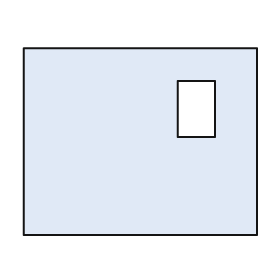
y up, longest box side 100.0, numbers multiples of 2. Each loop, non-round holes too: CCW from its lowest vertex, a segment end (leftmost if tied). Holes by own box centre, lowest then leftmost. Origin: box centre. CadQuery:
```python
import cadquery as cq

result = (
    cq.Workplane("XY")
    .moveTo(-50.0, -40.0)
    .lineTo(50.0, -40.0)
    .lineTo(50.0, 40.0)
    .lineTo(-50.0, 40.0)
    .close()
    .moveTo(16.0, 2.0)
    .lineTo(32.0, 2.0)
    .lineTo(32.0, 26.0)
    .lineTo(16.0, 26.0)
    .close()
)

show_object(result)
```